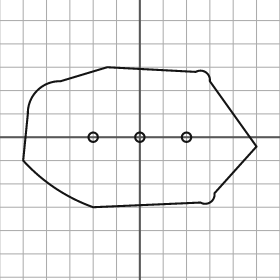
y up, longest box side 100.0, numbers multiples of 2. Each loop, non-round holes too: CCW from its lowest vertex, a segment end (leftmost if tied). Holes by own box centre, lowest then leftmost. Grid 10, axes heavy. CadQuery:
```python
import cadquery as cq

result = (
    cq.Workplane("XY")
    .moveTo(-20.0, -30.0)
    .lineTo(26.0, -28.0)
    .threePointArc((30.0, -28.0), (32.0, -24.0))
    .lineTo(50.0, -4.0)
    .lineTo(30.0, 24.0)
    .threePointArc((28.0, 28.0), (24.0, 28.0))
    .lineTo(-14.0, 30.0)
    .lineTo(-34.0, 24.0)
    .threePointArc((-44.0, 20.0), (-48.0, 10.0))
    .lineTo(-50.0, -10.0)
    .threePointArc((-36.0, -22.0), (-20.0, -30.0))
    .close()
    .moveTo(-20.0, 0.0)
    .circle(2.0)
    .moveTo(0.0, 0.0)
    .circle(2.0)
    .moveTo(20.0, 0.0)
    .circle(2.0)
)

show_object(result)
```